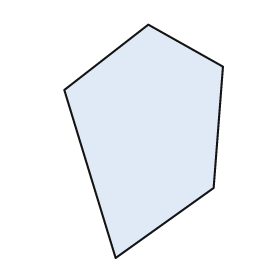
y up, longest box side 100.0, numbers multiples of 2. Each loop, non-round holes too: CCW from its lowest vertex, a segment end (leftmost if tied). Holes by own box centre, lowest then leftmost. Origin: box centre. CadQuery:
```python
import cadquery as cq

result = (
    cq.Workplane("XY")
    .moveTo(-12.0, -50.0)
    .lineTo(30.0, -20.0)
    .lineTo(34.0, 32.0)
    .lineTo(2.0, 50.0)
    .lineTo(-34.0, 22.0)
    .close()
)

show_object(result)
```